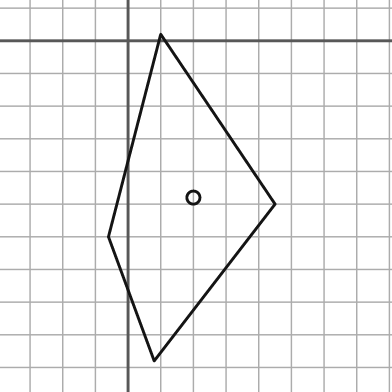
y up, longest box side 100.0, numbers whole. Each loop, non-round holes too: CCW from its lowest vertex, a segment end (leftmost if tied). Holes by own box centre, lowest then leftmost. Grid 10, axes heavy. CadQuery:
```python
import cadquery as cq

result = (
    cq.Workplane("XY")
    .moveTo(8.0, -98.0)
    .lineTo(45.0, -50.0)
    .lineTo(10.0, 2.0)
    .lineTo(-6.0, -60.0)
    .close()
    .moveTo(20.0, -48.0)
    .circle(2.0)
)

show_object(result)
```